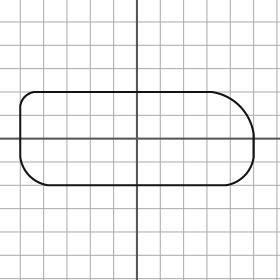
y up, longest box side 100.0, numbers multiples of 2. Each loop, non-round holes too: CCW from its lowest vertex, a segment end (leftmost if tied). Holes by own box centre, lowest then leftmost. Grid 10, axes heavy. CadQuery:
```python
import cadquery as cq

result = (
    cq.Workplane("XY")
    .moveTo(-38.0, -20.0)
    .lineTo(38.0, -20.0)
    .threePointArc((46.0, -16.0), (50.0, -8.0))
    .lineTo(50.0, 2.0)
    .threePointArc((44.0, 14.0), (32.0, 20.0))
    .lineTo(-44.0, 20.0)
    .threePointArc((-48.0, 18.0), (-50.0, 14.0))
    .lineTo(-50.0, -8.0)
    .threePointArc((-46.0, -16.0), (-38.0, -20.0))
    .close()
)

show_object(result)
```